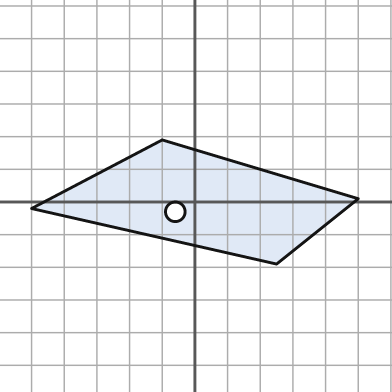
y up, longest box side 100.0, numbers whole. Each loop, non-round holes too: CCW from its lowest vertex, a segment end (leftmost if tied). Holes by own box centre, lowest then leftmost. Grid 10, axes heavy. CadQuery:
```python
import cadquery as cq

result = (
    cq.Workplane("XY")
    .moveTo(25.0, -19.0)
    .lineTo(50.0, 1.0)
    .lineTo(-10.0, 19.0)
    .lineTo(-50.0, -2.0)
    .close()
    .moveTo(-6.0, -3.0)
    .circle(3.0)
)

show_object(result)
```